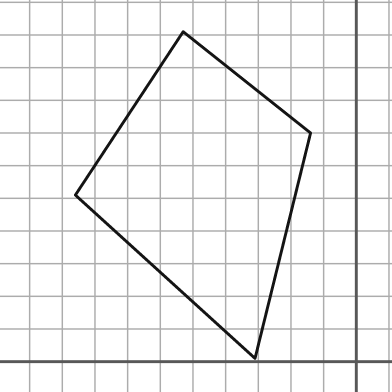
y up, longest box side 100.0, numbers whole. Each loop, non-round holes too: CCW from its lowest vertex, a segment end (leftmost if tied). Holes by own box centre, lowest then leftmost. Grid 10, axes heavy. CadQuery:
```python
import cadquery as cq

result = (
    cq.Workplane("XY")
    .moveTo(-31.0, 1.0)
    .lineTo(-14.0, 70.0)
    .lineTo(-53.0, 101.0)
    .lineTo(-86.0, 51.0)
    .close()
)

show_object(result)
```